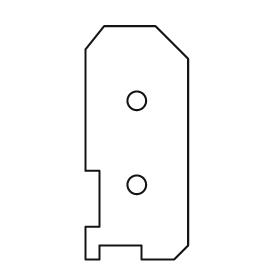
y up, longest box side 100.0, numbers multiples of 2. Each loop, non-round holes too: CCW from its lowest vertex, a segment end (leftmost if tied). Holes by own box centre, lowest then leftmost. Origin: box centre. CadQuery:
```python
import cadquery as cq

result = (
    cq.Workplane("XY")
    .moveTo(-22.0, -50.0)
    .lineTo(-16.0, -50.0)
    .lineTo(-16.0, -44.0)
    .lineTo(2.0, -44.0)
    .lineTo(2.0, -50.0)
    .lineTo(16.0, -50.0)
    .lineTo(22.0, -44.0)
    .lineTo(22.0, 36.0)
    .lineTo(8.0, 50.0)
    .lineTo(-14.0, 50.0)
    .lineTo(-22.0, 40.0)
    .lineTo(-22.0, -12.0)
    .lineTo(-16.0, -12.0)
    .lineTo(-16.0, -36.0)
    .lineTo(-22.0, -36.0)
    .close()
    .moveTo(0.0, -18.0)
    .circle(4.0)
    .moveTo(0.0, 18.0)
    .circle(4.0)
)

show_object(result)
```